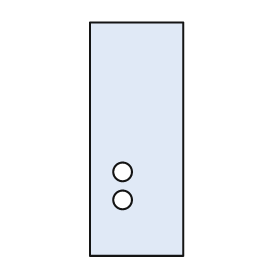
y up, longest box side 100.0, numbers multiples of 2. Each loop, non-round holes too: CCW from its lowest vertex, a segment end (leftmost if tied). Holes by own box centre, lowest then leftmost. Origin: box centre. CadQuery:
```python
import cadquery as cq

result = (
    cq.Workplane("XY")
    .moveTo(-20.0, -50.0)
    .lineTo(20.0, -50.0)
    .lineTo(20.0, 50.0)
    .lineTo(-20.0, 50.0)
    .close()
    .moveTo(-6.0, -26.0)
    .circle(4.0)
    .moveTo(-6.0, -14.0)
    .circle(4.0)
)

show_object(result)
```